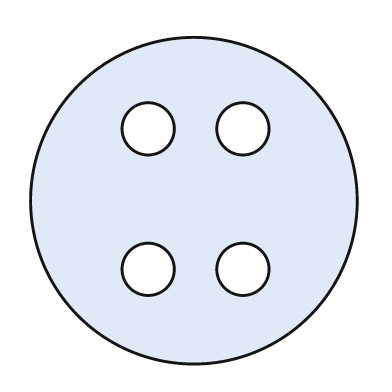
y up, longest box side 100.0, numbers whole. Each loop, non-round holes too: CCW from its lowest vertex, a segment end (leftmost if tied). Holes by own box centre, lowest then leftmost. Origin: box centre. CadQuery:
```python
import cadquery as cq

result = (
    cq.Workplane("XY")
    .moveTo(0.0, 0.0)
    .circle(50.0)
    .moveTo(-14.0, -21.0)
    .circle(8.0)
    .moveTo(15.0, -21.0)
    .circle(8.0)
    .moveTo(-14.0, 22.0)
    .circle(8.0)
    .moveTo(15.0, 22.0)
    .circle(8.0)
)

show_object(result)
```